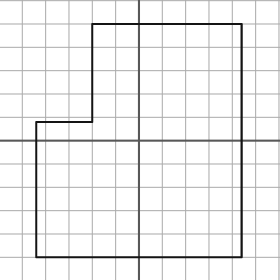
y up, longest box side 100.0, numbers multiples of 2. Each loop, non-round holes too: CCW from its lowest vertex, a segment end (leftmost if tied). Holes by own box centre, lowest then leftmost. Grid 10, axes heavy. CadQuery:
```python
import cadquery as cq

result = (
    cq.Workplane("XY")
    .moveTo(-44.0, -50.0)
    .lineTo(44.0, -50.0)
    .lineTo(44.0, 50.0)
    .lineTo(-20.0, 50.0)
    .lineTo(-20.0, 8.0)
    .lineTo(-44.0, 8.0)
    .close()
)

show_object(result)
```